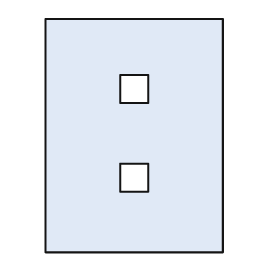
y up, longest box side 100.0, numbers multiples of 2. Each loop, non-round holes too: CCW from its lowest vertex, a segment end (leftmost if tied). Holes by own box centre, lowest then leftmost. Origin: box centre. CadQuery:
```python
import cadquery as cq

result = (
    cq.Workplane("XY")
    .moveTo(-38.0, -50.0)
    .lineTo(38.0, -50.0)
    .lineTo(38.0, 50.0)
    .lineTo(-38.0, 50.0)
    .close()
    .moveTo(-6.0, -24.0)
    .lineTo(6.0, -24.0)
    .lineTo(6.0, -12.0)
    .lineTo(-6.0, -12.0)
    .close()
    .moveTo(-6.0, 14.0)
    .lineTo(6.0, 14.0)
    .lineTo(6.0, 26.0)
    .lineTo(-6.0, 26.0)
    .close()
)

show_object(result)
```